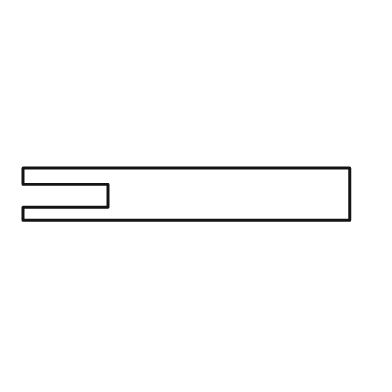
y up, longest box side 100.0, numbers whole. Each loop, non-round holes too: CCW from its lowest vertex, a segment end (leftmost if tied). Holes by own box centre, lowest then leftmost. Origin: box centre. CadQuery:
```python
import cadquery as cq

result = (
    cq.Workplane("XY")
    .moveTo(-50.0, -8.0)
    .lineTo(50.0, -8.0)
    .lineTo(50.0, 8.0)
    .lineTo(-50.0, 8.0)
    .lineTo(-50.0, 3.0)
    .lineTo(-24.0, 3.0)
    .lineTo(-24.0, -4.0)
    .lineTo(-50.0, -4.0)
    .close()
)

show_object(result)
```